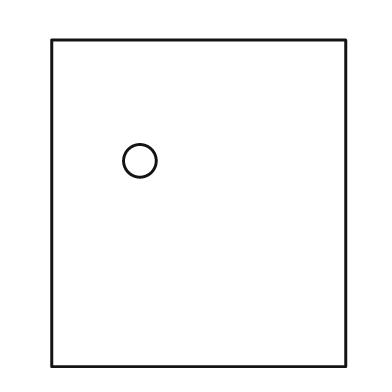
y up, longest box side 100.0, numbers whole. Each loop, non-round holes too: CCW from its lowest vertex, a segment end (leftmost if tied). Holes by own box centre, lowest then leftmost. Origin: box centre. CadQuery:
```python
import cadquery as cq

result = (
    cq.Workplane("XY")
    .moveTo(-45.0, -50.0)
    .lineTo(45.0, -50.0)
    .lineTo(45.0, 50.0)
    .lineTo(-45.0, 50.0)
    .close()
    .moveTo(-18.0, 13.0)
    .circle(5.0)
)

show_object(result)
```